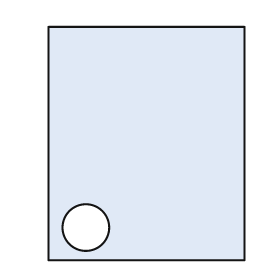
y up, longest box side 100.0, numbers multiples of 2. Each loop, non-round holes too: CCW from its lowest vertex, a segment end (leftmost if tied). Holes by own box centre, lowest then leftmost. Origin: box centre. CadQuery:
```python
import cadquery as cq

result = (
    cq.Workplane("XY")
    .moveTo(-42.0, -50.0)
    .lineTo(42.0, -50.0)
    .lineTo(42.0, 50.0)
    .lineTo(-42.0, 50.0)
    .close()
    .moveTo(-26.0, -36.0)
    .circle(10.0)
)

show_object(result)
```